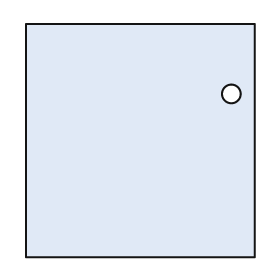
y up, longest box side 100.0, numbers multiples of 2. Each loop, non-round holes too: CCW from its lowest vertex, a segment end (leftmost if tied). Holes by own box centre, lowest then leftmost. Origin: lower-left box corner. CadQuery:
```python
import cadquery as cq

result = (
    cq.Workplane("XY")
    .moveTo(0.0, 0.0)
    .lineTo(98.0, 0.0)
    .lineTo(98.0, 100.0)
    .lineTo(0.0, 100.0)
    .close()
    .moveTo(88.0, 70.0)
    .circle(4.0)
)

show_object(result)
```